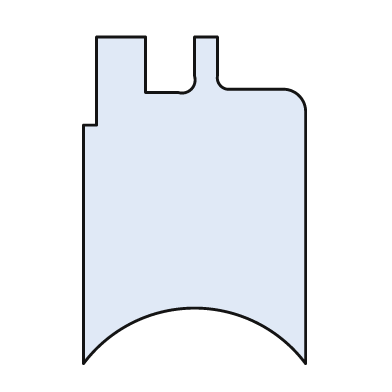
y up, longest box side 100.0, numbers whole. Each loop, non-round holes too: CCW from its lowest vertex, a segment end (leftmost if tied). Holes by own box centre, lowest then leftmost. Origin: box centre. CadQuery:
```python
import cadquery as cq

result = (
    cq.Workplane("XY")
    .moveTo(-34.0, -50.0)
    .threePointArc((0.0, -33.0), (34.0, -50.0))
    .lineTo(34.0, 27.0)
    .threePointArc((32.0, 32.0), (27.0, 34.0))
    .lineTo(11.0, 34.0)
    .threePointArc((8.0, 35.0), (7.0, 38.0))
    .lineTo(7.0, 50.0)
    .lineTo(0.0, 50.0)
    .lineTo(0.0, 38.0)
    .threePointArc((-1.0, 34.0), (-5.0, 33.0))
    .lineTo(-15.0, 33.0)
    .lineTo(-15.0, 50.0)
    .lineTo(-30.0, 50.0)
    .lineTo(-30.0, 23.0)
    .lineTo(-34.0, 23.0)
    .close()
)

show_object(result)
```